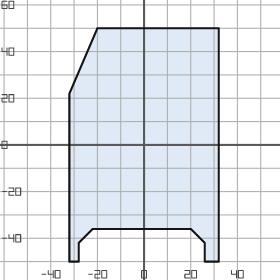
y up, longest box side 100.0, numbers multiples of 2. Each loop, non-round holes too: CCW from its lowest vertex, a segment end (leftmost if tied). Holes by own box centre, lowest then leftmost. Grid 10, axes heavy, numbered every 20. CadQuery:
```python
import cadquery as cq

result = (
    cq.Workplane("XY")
    .moveTo(-32.0, -50.0)
    .lineTo(-28.0, -50.0)
    .lineTo(-28.0, -42.0)
    .lineTo(-22.0, -36.0)
    .lineTo(20.0, -36.0)
    .lineTo(26.0, -42.0)
    .lineTo(26.0, -50.0)
    .lineTo(32.0, -50.0)
    .lineTo(32.0, 50.0)
    .lineTo(-20.0, 50.0)
    .lineTo(-32.0, 22.0)
    .close()
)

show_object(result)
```